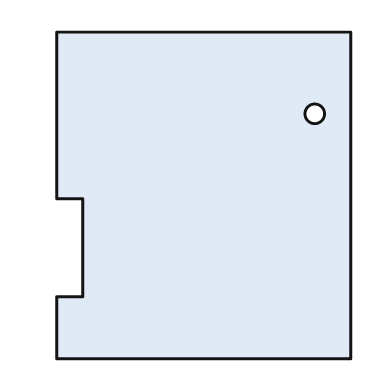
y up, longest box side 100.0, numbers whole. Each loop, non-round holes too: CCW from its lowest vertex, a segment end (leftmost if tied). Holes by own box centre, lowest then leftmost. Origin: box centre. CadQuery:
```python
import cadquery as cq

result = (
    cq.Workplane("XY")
    .moveTo(-45.0, -50.0)
    .lineTo(45.0, -50.0)
    .lineTo(45.0, 50.0)
    .lineTo(-45.0, 50.0)
    .lineTo(-45.0, -1.0)
    .lineTo(-37.0, -1.0)
    .lineTo(-37.0, -31.0)
    .lineTo(-45.0, -31.0)
    .close()
    .moveTo(34.0, 25.0)
    .circle(3.0)
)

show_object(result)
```